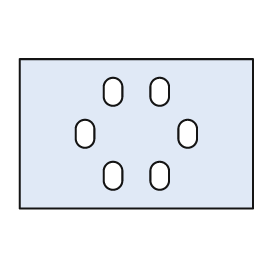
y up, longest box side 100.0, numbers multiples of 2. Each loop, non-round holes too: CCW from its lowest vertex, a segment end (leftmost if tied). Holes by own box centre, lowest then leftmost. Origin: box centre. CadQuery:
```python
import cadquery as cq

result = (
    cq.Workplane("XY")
    .moveTo(-50.0, -32.0)
    .lineTo(50.0, -32.0)
    .lineTo(50.0, 32.0)
    .lineTo(-50.0, 32.0)
    .close()
    .moveTo(-14.0, -20.0)
    .threePointArc((-10.0, -24.0), (-6.0, -20.0))
    .lineTo(-6.0, -16.0)
    .threePointArc((-10.0, -12.0), (-14.0, -16.0))
    .close()
    .moveTo(6.0, -20.0)
    .threePointArc((10.0, -24.0), (14.0, -20.0))
    .lineTo(14.0, -16.0)
    .threePointArc((10.0, -12.0), (6.0, -16.0))
    .close()
    .moveTo(-26.0, -2.0)
    .threePointArc((-22.0, -6.0), (-18.0, -2.0))
    .lineTo(-18.0, 2.0)
    .threePointArc((-22.0, 6.0), (-26.0, 2.0))
    .close()
    .moveTo(18.0, -2.0)
    .threePointArc((22.0, -6.0), (26.0, -2.0))
    .lineTo(26.0, 2.0)
    .threePointArc((22.0, 6.0), (18.0, 2.0))
    .close()
    .moveTo(-14.0, 16.0)
    .threePointArc((-10.0, 12.0), (-6.0, 16.0))
    .lineTo(-6.0, 20.0)
    .threePointArc((-10.0, 24.0), (-14.0, 20.0))
    .close()
    .moveTo(6.0, 16.0)
    .threePointArc((10.0, 12.0), (14.0, 16.0))
    .lineTo(14.0, 20.0)
    .threePointArc((10.0, 24.0), (6.0, 20.0))
    .close()
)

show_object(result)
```